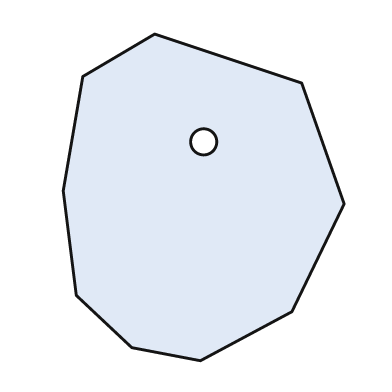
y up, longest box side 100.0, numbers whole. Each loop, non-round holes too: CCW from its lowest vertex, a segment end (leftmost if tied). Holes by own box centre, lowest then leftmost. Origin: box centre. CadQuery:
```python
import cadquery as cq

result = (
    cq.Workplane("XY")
    .moveTo(-1.0, -50.0)
    .lineTo(27.0, -35.0)
    .lineTo(43.0, -2.0)
    .lineTo(30.0, 35.0)
    .lineTo(-15.0, 50.0)
    .lineTo(-37.0, 37.0)
    .lineTo(-43.0, 2.0)
    .lineTo(-39.0, -30.0)
    .lineTo(-22.0, -46.0)
    .close()
    .moveTo(0.0, 17.0)
    .circle(4.0)
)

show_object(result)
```